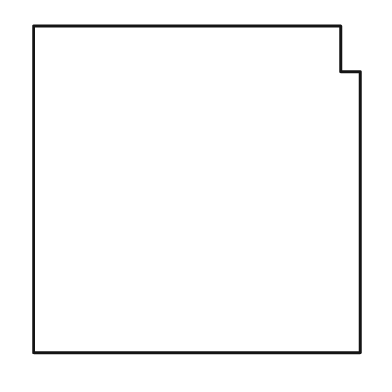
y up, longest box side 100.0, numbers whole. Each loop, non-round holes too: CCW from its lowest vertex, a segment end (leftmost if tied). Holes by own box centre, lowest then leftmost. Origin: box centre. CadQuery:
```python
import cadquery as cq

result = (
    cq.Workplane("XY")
    .moveTo(-50.0, -50.0)
    .lineTo(50.0, -50.0)
    .lineTo(50.0, 36.0)
    .lineTo(44.0, 36.0)
    .lineTo(44.0, 50.0)
    .lineTo(-50.0, 50.0)
    .close()
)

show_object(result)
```